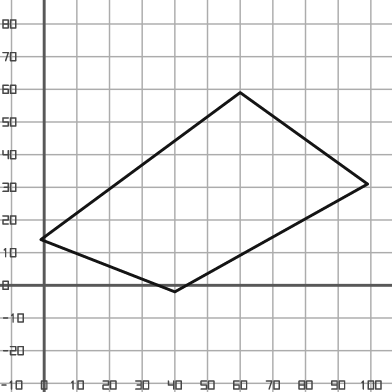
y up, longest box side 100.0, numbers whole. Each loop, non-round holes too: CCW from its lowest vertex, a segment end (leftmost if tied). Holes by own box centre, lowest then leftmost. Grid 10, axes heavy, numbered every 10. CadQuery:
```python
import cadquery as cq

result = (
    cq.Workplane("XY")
    .moveTo(40.0, -2.0)
    .lineTo(99.0, 31.0)
    .lineTo(60.0, 59.0)
    .lineTo(-1.0, 14.0)
    .close()
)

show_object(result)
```